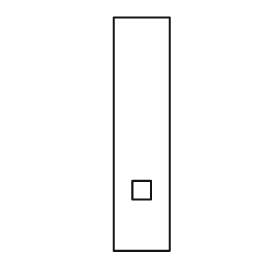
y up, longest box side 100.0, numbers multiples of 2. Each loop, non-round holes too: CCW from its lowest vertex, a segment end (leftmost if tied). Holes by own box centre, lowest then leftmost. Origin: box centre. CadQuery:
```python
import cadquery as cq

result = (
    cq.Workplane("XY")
    .moveTo(-12.0, -50.0)
    .lineTo(12.0, -50.0)
    .lineTo(12.0, 50.0)
    .lineTo(-12.0, 50.0)
    .close()
    .moveTo(-4.0, -28.0)
    .lineTo(4.0, -28.0)
    .lineTo(4.0, -20.0)
    .lineTo(-4.0, -20.0)
    .close()
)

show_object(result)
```